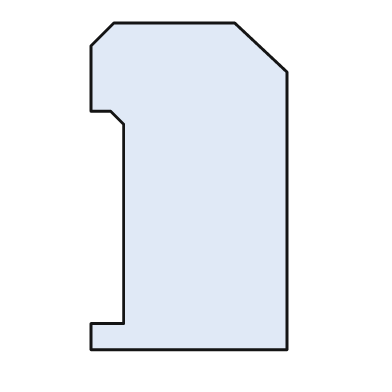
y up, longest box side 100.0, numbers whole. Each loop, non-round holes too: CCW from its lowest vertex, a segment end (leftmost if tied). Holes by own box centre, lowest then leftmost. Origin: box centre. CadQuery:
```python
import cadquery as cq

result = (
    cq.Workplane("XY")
    .moveTo(-30.0, -50.0)
    .lineTo(30.0, -50.0)
    .lineTo(30.0, 35.0)
    .lineTo(14.0, 50.0)
    .lineTo(-23.0, 50.0)
    .lineTo(-30.0, 43.0)
    .lineTo(-30.0, 23.0)
    .lineTo(-24.0, 23.0)
    .lineTo(-20.0, 19.0)
    .lineTo(-20.0, -42.0)
    .lineTo(-30.0, -42.0)
    .close()
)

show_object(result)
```